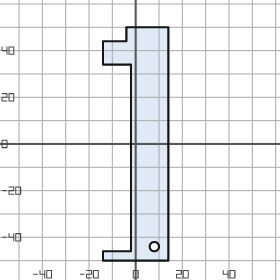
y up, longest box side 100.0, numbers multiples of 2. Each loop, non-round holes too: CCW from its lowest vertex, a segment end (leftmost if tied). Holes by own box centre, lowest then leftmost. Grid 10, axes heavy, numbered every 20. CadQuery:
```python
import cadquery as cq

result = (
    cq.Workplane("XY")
    .moveTo(-14.0, -50.0)
    .lineTo(14.0, -50.0)
    .lineTo(14.0, 50.0)
    .lineTo(-4.0, 50.0)
    .lineTo(-4.0, 44.0)
    .lineTo(-14.0, 44.0)
    .lineTo(-14.0, 34.0)
    .lineTo(-2.0, 34.0)
    .lineTo(-2.0, -46.0)
    .lineTo(-14.0, -46.0)
    .close()
    .moveTo(8.0, -44.0)
    .circle(2.0)
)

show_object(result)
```